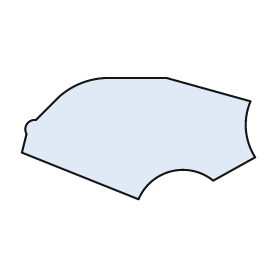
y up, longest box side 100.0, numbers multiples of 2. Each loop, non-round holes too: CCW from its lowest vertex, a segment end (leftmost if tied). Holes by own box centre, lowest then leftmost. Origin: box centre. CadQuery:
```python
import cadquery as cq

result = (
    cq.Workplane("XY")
    .moveTo(0.0, -26.0)
    .threePointArc((14.0, -14.0), (32.0, -18.0))
    .lineTo(50.0, -8.0)
    .threePointArc((46.0, 4.0), (48.0, 16.0))
    .lineTo(12.0, 26.0)
    .lineTo(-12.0, 26.0)
    .threePointArc((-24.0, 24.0), (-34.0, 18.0))
    .lineTo(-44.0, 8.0)
    .threePointArc((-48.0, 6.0), (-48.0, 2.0))
    .lineTo(-50.0, -6.0)
    .close()
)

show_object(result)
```